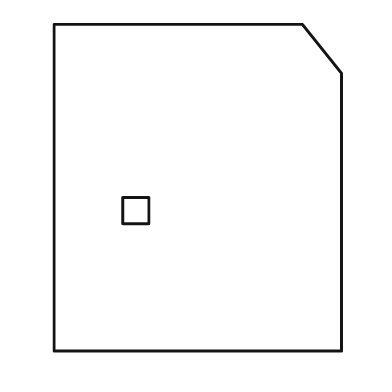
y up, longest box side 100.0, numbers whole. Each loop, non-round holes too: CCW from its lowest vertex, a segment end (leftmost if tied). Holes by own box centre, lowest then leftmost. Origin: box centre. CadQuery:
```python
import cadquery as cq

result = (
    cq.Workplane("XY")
    .moveTo(-44.0, -50.0)
    .lineTo(44.0, -50.0)
    .lineTo(44.0, 35.0)
    .lineTo(32.0, 50.0)
    .lineTo(-44.0, 50.0)
    .close()
    .moveTo(-23.0, -11.0)
    .lineTo(-15.0, -11.0)
    .lineTo(-15.0, -3.0)
    .lineTo(-23.0, -3.0)
    .close()
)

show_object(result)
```